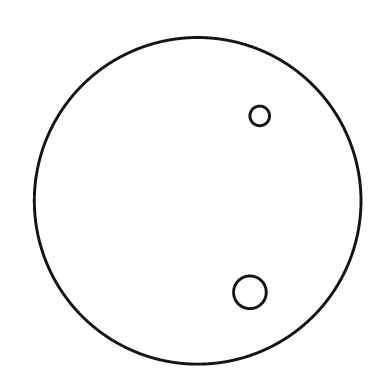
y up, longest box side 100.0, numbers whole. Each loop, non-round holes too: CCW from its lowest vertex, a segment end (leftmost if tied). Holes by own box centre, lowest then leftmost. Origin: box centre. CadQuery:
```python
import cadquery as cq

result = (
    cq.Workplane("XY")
    .moveTo(0.0, 0.0)
    .circle(50.0)
    .moveTo(16.0, -28.0)
    .circle(5.0)
    .moveTo(19.0, 26.0)
    .circle(3.0)
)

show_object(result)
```